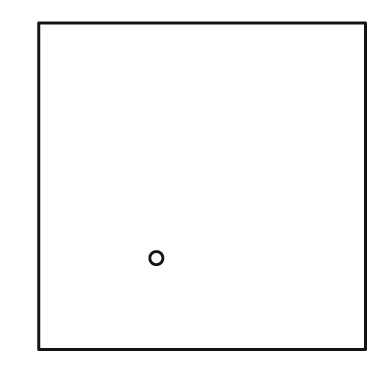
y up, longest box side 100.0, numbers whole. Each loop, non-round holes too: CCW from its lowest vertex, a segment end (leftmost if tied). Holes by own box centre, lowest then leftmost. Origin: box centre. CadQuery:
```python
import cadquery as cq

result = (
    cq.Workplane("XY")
    .moveTo(-50.0, -50.0)
    .lineTo(50.0, -50.0)
    .lineTo(50.0, 50.0)
    .lineTo(-50.0, 50.0)
    .close()
    .moveTo(-14.0, -22.0)
    .circle(2.0)
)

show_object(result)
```